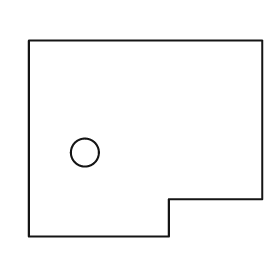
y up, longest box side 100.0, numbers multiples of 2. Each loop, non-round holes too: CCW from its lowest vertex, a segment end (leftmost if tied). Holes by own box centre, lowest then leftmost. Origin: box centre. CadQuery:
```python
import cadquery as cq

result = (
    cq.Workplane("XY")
    .moveTo(-50.0, -42.0)
    .lineTo(10.0, -42.0)
    .lineTo(10.0, -26.0)
    .lineTo(50.0, -26.0)
    .lineTo(50.0, 42.0)
    .lineTo(-50.0, 42.0)
    .close()
    .moveTo(-26.0, -6.0)
    .circle(6.0)
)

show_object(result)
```